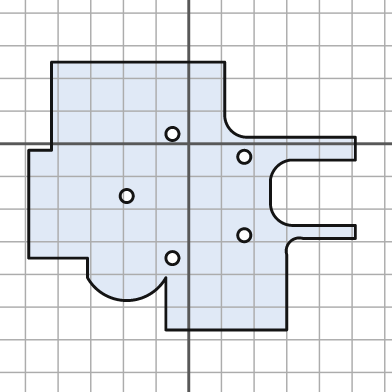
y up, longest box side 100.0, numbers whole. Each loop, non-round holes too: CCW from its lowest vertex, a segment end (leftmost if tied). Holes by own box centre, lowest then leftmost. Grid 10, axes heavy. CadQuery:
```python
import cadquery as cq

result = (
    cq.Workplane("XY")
    .moveTo(-7.0, -57.0)
    .lineTo(30.0, -57.0)
    .lineTo(30.0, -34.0)
    .threePointArc((31.0, -30.0), (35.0, -29.0))
    .lineTo(51.0, -29.0)
    .lineTo(51.0, -25.0)
    .lineTo(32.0, -25.0)
    .threePointArc((27.0, -23.0), (25.0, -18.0))
    .lineTo(25.0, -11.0)
    .threePointArc((27.0, -7.0), (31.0, -5.0))
    .lineTo(51.0, -5.0)
    .lineTo(51.0, 2.0)
    .lineTo(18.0, 2.0)
    .threePointArc((13.0, 4.0), (11.0, 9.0))
    .lineTo(11.0, 25.0)
    .lineTo(-42.0, 25.0)
    .lineTo(-42.0, -2.0)
    .lineTo(-49.0, -2.0)
    .lineTo(-49.0, -35.0)
    .lineTo(-31.0, -35.0)
    .lineTo(-31.0, -41.0)
    .threePointArc((-19.0, -48.0), (-7.0, -41.0))
    .close()
    .moveTo(-5.0, -35.0)
    .circle(2.0)
    .moveTo(17.0, -28.0)
    .circle(2.0)
    .moveTo(-19.0, -16.0)
    .circle(2.0)
    .moveTo(17.0, -4.0)
    .circle(2.0)
    .moveTo(-5.0, 3.0)
    .circle(2.0)
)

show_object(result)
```